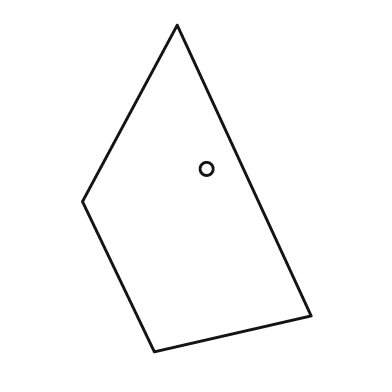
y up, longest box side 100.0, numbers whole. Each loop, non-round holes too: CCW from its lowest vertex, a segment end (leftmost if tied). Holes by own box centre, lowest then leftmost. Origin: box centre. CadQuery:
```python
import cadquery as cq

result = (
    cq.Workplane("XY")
    .moveTo(-13.0, -50.0)
    .lineTo(35.0, -39.0)
    .lineTo(-6.0, 50.0)
    .lineTo(-35.0, -4.0)
    .close()
    .moveTo(3.0, 6.0)
    .circle(2.0)
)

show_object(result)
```